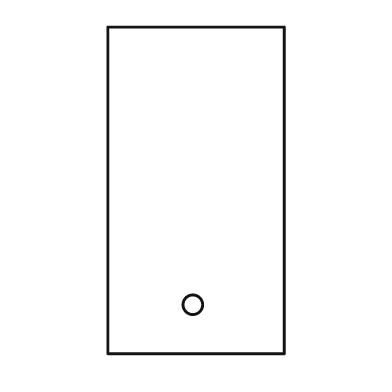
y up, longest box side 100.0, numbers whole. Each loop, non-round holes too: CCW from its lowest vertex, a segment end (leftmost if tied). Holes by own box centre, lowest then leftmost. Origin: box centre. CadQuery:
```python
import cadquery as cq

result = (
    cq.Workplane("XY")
    .moveTo(-27.0, -50.0)
    .lineTo(27.0, -50.0)
    .lineTo(27.0, 50.0)
    .lineTo(-27.0, 50.0)
    .close()
    .moveTo(-1.0, -35.0)
    .circle(3.0)
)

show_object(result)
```